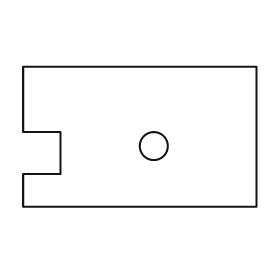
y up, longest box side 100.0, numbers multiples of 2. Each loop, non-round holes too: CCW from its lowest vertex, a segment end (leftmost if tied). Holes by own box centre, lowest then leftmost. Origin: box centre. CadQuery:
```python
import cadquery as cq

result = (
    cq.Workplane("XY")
    .moveTo(-50.0, -30.0)
    .lineTo(50.0, -30.0)
    .lineTo(50.0, 30.0)
    .lineTo(-50.0, 30.0)
    .lineTo(-50.0, 2.0)
    .lineTo(-34.0, 2.0)
    .lineTo(-34.0, -16.0)
    .lineTo(-50.0, -16.0)
    .close()
    .moveTo(6.0, -4.0)
    .circle(6.0)
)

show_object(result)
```